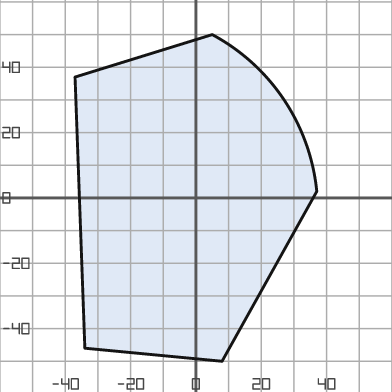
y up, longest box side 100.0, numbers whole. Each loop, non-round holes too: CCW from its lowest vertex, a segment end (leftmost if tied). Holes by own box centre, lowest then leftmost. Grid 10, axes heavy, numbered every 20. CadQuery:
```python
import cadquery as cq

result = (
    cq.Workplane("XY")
    .moveTo(8.0, -50.0)
    .lineTo(37.0, 2.0)
    .threePointArc((27.0, 30.0), (5.0, 50.0))
    .lineTo(-37.0, 37.0)
    .lineTo(-34.0, -46.0)
    .close()
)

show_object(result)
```